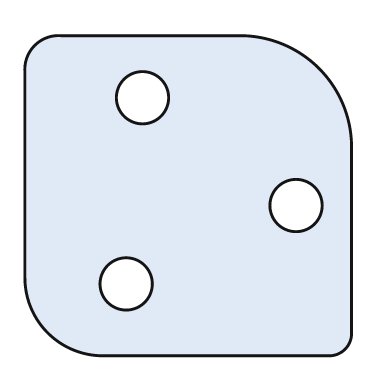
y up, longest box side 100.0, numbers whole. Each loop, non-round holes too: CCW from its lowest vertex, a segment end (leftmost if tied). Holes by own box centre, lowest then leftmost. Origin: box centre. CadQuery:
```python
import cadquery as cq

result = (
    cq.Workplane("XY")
    .moveTo(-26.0, -49.0)
    .lineTo(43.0, -49.0)
    .threePointArc((48.0, -47.0), (50.0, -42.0))
    .lineTo(50.0, 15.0)
    .threePointArc((40.0, 39.0), (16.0, 49.0))
    .lineTo(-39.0, 49.0)
    .threePointArc((-47.0, 46.0), (-50.0, 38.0))
    .lineTo(-50.0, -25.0)
    .threePointArc((-43.0, -42.0), (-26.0, -49.0))
    .close()
    .moveTo(-19.0, -27.0)
    .circle(8.0)
    .moveTo(33.0, -3.0)
    .circle(8.0)
    .moveTo(-14.0, 30.0)
    .circle(8.0)
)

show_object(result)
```